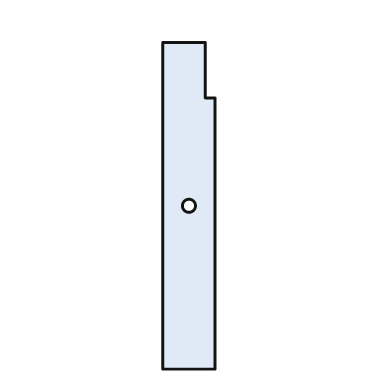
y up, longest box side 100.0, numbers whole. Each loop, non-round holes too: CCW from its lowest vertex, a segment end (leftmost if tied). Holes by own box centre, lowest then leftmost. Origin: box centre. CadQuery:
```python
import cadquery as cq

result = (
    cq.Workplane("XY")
    .moveTo(-8.0, -50.0)
    .lineTo(8.0, -50.0)
    .lineTo(8.0, 33.0)
    .lineTo(5.0, 33.0)
    .lineTo(5.0, 50.0)
    .lineTo(-8.0, 50.0)
    .close()
    .moveTo(0.0, 0.0)
    .circle(2.0)
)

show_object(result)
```